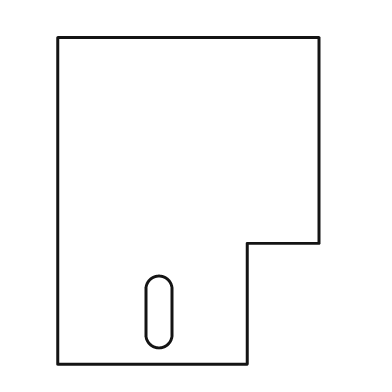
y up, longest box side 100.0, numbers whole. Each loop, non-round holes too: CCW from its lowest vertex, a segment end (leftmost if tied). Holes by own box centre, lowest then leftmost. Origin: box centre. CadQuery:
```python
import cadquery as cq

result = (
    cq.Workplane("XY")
    .moveTo(-40.0, -50.0)
    .lineTo(18.0, -50.0)
    .lineTo(18.0, -13.0)
    .lineTo(40.0, -13.0)
    .lineTo(40.0, 50.0)
    .lineTo(-40.0, 50.0)
    .close()
    .moveTo(-13.0, -41.0)
    .threePointArc((-9.0, -45.0), (-5.0, -41.0))
    .lineTo(-5.0, -27.0)
    .threePointArc((-9.0, -23.0), (-13.0, -27.0))
    .close()
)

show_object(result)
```